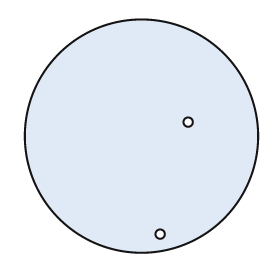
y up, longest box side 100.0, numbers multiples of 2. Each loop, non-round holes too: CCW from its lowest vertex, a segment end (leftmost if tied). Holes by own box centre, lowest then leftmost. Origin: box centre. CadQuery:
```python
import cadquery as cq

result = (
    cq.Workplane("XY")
    .moveTo(0.0, 0.0)
    .circle(50.0)
    .moveTo(8.0, -42.0)
    .circle(2.0)
    .moveTo(20.0, 6.0)
    .circle(2.0)
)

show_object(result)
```